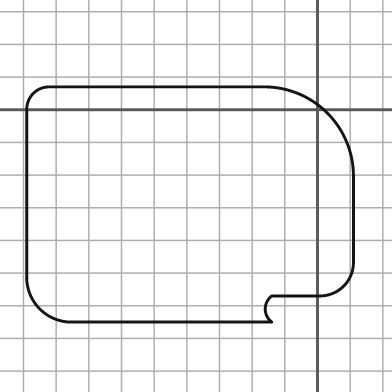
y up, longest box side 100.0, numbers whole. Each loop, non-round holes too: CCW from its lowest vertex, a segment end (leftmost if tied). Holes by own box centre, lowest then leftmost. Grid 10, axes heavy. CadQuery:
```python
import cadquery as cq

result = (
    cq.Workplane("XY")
    .moveTo(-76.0, -65.0)
    .lineTo(-14.0, -65.0)
    .threePointArc((-16.0, -61.0), (-14.0, -57.0))
    .lineTo(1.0, -57.0)
    .threePointArc((8.0, -54.0), (11.0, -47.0))
    .lineTo(11.0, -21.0)
    .threePointArc((3.0, -1.0), (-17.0, 7.0))
    .lineTo(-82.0, 7.0)
    .threePointArc((-87.0, 5.0), (-89.0, 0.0))
    .lineTo(-89.0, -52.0)
    .threePointArc((-85.0, -61.0), (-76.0, -65.0))
    .close()
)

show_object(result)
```